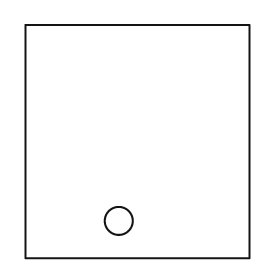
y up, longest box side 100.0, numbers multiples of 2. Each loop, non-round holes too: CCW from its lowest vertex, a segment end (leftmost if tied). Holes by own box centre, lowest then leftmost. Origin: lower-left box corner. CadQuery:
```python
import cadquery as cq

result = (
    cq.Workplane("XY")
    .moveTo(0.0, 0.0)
    .lineTo(96.0, 0.0)
    .lineTo(96.0, 100.0)
    .lineTo(0.0, 100.0)
    .close()
    .moveTo(40.0, 16.0)
    .circle(6.0)
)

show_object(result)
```